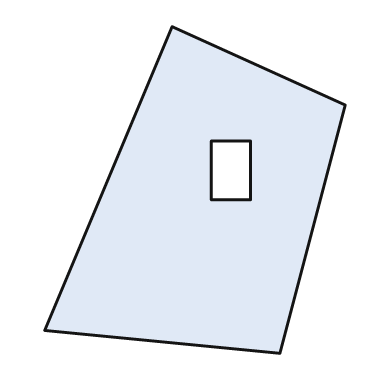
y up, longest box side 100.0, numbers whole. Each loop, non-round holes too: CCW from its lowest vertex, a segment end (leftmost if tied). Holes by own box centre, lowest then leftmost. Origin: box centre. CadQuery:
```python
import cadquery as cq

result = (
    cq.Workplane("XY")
    .moveTo(26.0, -50.0)
    .lineTo(46.0, 26.0)
    .lineTo(-7.0, 50.0)
    .lineTo(-46.0, -43.0)
    .close()
    .moveTo(5.0, -3.0)
    .lineTo(17.0, -3.0)
    .lineTo(17.0, 15.0)
    .lineTo(5.0, 15.0)
    .close()
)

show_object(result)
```